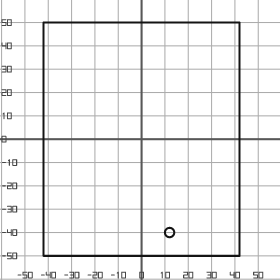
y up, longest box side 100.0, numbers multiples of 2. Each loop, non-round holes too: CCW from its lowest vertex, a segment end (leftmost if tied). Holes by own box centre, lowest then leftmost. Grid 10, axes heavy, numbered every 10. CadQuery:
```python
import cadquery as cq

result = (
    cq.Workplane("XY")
    .moveTo(-42.0, -50.0)
    .lineTo(42.0, -50.0)
    .lineTo(42.0, 50.0)
    .lineTo(-42.0, 50.0)
    .close()
    .moveTo(12.0, -40.0)
    .circle(2.0)
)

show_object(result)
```